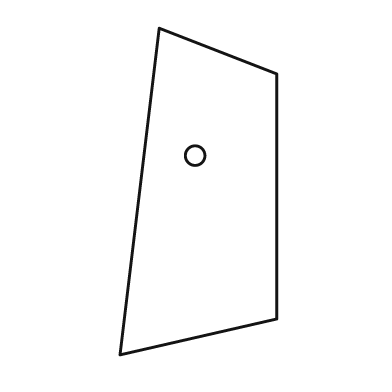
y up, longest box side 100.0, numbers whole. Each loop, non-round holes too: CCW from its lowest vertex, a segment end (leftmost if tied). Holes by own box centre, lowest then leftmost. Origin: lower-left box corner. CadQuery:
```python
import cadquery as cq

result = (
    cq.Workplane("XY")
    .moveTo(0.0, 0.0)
    .lineTo(48.0, 11.0)
    .lineTo(48.0, 86.0)
    .lineTo(12.0, 100.0)
    .close()
    .moveTo(23.0, 61.0)
    .circle(3.0)
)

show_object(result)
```